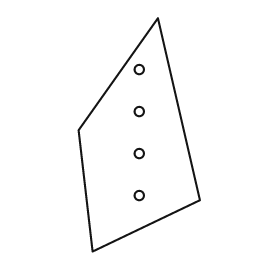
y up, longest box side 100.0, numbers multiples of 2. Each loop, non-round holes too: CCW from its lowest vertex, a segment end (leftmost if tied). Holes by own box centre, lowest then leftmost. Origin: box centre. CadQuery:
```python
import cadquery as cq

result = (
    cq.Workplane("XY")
    .moveTo(-20.0, -50.0)
    .lineTo(26.0, -28.0)
    .lineTo(8.0, 50.0)
    .lineTo(-26.0, 2.0)
    .close()
    .moveTo(0.0, -26.0)
    .circle(2.0)
    .moveTo(0.0, -8.0)
    .circle(2.0)
    .moveTo(0.0, 10.0)
    .circle(2.0)
    .moveTo(0.0, 28.0)
    .circle(2.0)
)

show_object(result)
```